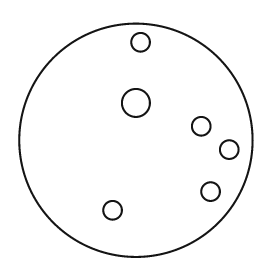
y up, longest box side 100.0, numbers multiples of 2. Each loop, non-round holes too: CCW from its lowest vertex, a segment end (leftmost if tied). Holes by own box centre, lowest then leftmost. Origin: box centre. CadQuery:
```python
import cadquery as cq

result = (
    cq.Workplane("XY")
    .moveTo(0.0, 0.0)
    .circle(50.0)
    .moveTo(-10.0, -30.0)
    .circle(4.0)
    .moveTo(32.0, -22.0)
    .circle(4.0)
    .moveTo(40.0, -4.0)
    .circle(4.0)
    .moveTo(28.0, 6.0)
    .circle(4.0)
    .moveTo(0.0, 16.0)
    .circle(6.0)
    .moveTo(2.0, 42.0)
    .circle(4.0)
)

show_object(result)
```